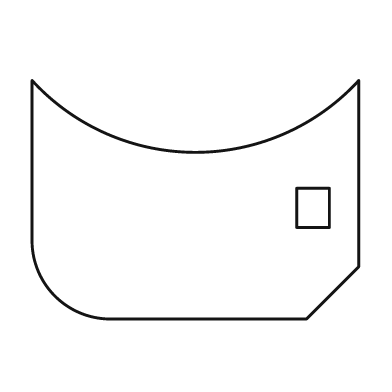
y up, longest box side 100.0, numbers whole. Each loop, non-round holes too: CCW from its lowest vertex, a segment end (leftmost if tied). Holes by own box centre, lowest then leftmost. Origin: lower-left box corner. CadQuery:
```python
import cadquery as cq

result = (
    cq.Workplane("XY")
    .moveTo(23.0, 0.0)
    .lineTo(84.0, 0.0)
    .lineTo(100.0, 16.0)
    .lineTo(100.0, 73.0)
    .threePointArc((50.0, 51.0), (0.0, 73.0))
    .lineTo(0.0, 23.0)
    .threePointArc((7.0, 7.0), (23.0, 0.0))
    .close()
    .moveTo(81.0, 28.0)
    .lineTo(91.0, 28.0)
    .lineTo(91.0, 40.0)
    .lineTo(81.0, 40.0)
    .close()
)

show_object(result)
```